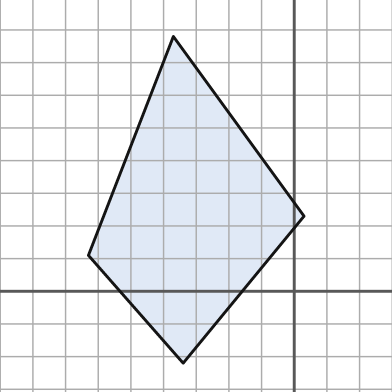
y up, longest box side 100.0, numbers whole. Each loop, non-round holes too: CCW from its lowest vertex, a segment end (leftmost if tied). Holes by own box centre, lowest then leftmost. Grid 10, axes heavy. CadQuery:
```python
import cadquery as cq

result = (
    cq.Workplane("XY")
    .moveTo(-34.0, -22.0)
    .lineTo(3.0, 23.0)
    .lineTo(-37.0, 78.0)
    .lineTo(-63.0, 11.0)
    .close()
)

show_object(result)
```